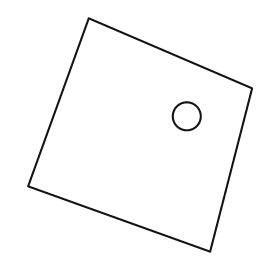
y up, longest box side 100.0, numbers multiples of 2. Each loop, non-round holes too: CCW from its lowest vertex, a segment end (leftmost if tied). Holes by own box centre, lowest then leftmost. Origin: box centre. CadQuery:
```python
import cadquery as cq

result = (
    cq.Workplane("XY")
    .moveTo(30.0, -50.0)
    .lineTo(48.0, 20.0)
    .lineTo(-22.0, 50.0)
    .lineTo(-48.0, -22.0)
    .close()
    .moveTo(20.0, 8.0)
    .circle(6.0)
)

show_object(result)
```